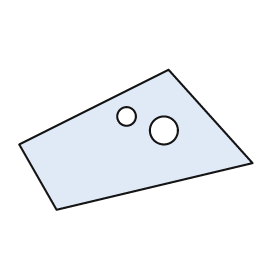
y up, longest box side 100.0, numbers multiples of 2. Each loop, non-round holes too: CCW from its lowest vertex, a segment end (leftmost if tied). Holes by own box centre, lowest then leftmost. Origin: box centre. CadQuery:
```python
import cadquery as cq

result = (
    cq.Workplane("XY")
    .moveTo(-34.0, -30.0)
    .lineTo(50.0, -10.0)
    .lineTo(14.0, 30.0)
    .lineTo(-50.0, -2.0)
    .close()
    .moveTo(12.0, 4.0)
    .circle(6.0)
    .moveTo(-4.0, 10.0)
    .circle(4.0)
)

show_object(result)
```